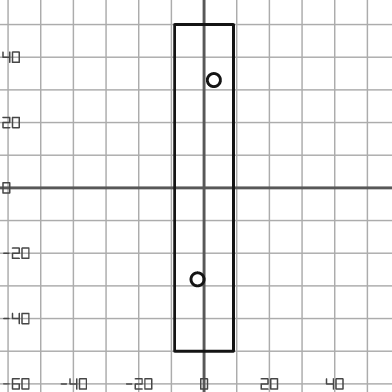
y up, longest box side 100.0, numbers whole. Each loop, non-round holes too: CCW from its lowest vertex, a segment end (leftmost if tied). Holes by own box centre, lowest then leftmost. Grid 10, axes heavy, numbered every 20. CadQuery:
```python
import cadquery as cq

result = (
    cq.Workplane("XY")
    .moveTo(-9.0, -50.0)
    .lineTo(9.0, -50.0)
    .lineTo(9.0, 50.0)
    .lineTo(-9.0, 50.0)
    .close()
    .moveTo(-2.0, -28.0)
    .circle(2.0)
    .moveTo(3.0, 33.0)
    .circle(2.0)
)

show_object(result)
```